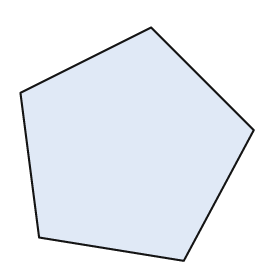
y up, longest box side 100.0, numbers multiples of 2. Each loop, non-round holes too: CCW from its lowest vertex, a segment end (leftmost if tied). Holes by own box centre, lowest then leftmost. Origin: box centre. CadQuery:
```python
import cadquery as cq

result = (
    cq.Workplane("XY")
    .moveTo(20.0, -50.0)
    .lineTo(50.0, 6.0)
    .lineTo(6.0, 50.0)
    .lineTo(-50.0, 22.0)
    .lineTo(-42.0, -40.0)
    .close()
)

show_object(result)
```